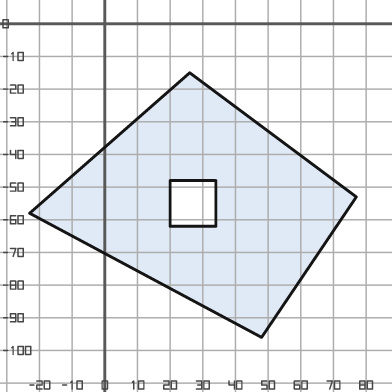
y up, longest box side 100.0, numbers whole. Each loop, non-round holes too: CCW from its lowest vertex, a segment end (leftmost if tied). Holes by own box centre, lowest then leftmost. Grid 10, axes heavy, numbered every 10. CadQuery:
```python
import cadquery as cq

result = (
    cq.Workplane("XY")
    .moveTo(48.0, -96.0)
    .lineTo(77.0, -53.0)
    .lineTo(26.0, -15.0)
    .lineTo(-23.0, -58.0)
    .close()
    .moveTo(20.0, -62.0)
    .lineTo(34.0, -62.0)
    .lineTo(34.0, -48.0)
    .lineTo(20.0, -48.0)
    .close()
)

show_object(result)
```